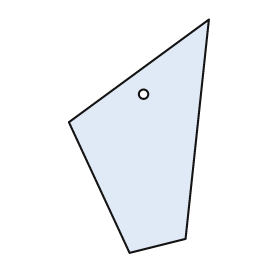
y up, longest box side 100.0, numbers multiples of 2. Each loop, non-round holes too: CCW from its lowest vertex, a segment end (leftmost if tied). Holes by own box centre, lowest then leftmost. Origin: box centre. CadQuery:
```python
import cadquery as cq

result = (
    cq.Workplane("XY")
    .moveTo(-4.0, -50.0)
    .lineTo(20.0, -44.0)
    .lineTo(30.0, 50.0)
    .lineTo(-30.0, 6.0)
    .close()
    .moveTo(2.0, 18.0)
    .circle(2.0)
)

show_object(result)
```